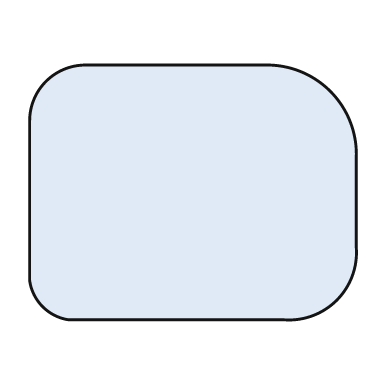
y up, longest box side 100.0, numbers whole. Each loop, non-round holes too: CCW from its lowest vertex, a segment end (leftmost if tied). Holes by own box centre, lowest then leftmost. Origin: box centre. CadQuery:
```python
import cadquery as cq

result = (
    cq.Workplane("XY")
    .moveTo(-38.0, -39.0)
    .lineTo(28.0, -39.0)
    .threePointArc((44.0, -33.0), (50.0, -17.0))
    .lineTo(50.0, 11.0)
    .threePointArc((42.0, 31.0), (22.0, 39.0))
    .lineTo(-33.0, 39.0)
    .threePointArc((-45.0, 34.0), (-50.0, 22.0))
    .lineTo(-50.0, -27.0)
    .threePointArc((-46.0, -35.0), (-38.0, -39.0))
    .close()
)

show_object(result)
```